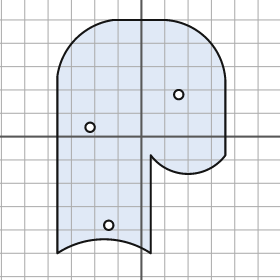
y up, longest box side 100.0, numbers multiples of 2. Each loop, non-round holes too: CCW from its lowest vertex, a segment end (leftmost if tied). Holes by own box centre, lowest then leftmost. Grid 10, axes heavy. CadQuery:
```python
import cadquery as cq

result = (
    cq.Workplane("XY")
    .moveTo(-36.0, -50.0)
    .threePointArc((-16.0, -44.0), (4.0, -50.0))
    .lineTo(4.0, -8.0)
    .threePointArc((20.0, -16.0), (36.0, -8.0))
    .lineTo(36.0, 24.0)
    .threePointArc((28.0, 42.0), (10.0, 50.0))
    .lineTo(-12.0, 50.0)
    .threePointArc((-28.0, 42.0), (-36.0, 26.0))
    .close()
    .moveTo(-14.0, -38.0)
    .circle(2.0)
    .moveTo(-22.0, 4.0)
    .circle(2.0)
    .moveTo(16.0, 18.0)
    .circle(2.0)
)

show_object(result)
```